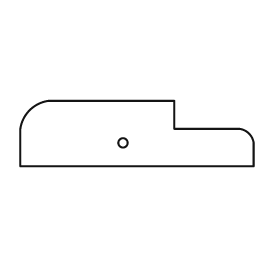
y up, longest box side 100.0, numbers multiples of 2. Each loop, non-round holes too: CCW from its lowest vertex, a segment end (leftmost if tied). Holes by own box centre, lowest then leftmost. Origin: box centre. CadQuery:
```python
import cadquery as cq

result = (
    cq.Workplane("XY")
    .moveTo(-50.0, -14.0)
    .lineTo(50.0, -14.0)
    .lineTo(50.0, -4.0)
    .threePointArc((48.0, 0.0), (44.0, 2.0))
    .lineTo(16.0, 2.0)
    .lineTo(16.0, 14.0)
    .lineTo(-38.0, 14.0)
    .threePointArc((-46.0, 10.0), (-50.0, 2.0))
    .close()
    .moveTo(-6.0, -4.0)
    .circle(2.0)
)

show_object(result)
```